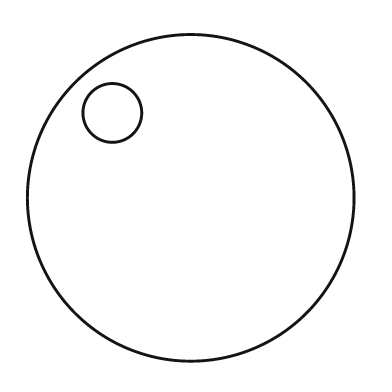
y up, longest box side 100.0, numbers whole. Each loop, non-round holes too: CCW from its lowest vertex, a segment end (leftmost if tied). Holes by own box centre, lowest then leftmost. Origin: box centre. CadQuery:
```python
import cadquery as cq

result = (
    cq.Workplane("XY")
    .moveTo(0.0, 0.0)
    .circle(50.0)
    .moveTo(-24.0, 26.0)
    .circle(9.0)
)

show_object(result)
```